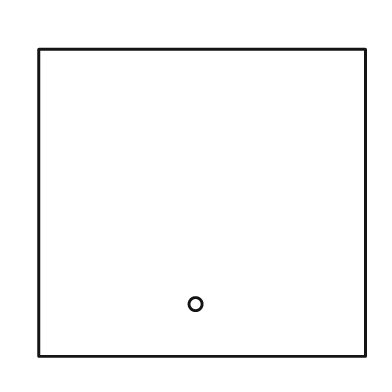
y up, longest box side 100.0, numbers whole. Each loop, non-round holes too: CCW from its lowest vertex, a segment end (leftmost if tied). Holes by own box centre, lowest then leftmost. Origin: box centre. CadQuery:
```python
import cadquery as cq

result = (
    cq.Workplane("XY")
    .moveTo(-50.0, -47.0)
    .lineTo(50.0, -47.0)
    .lineTo(50.0, 47.0)
    .lineTo(-50.0, 47.0)
    .close()
    .moveTo(-2.0, -31.0)
    .circle(2.0)
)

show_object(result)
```